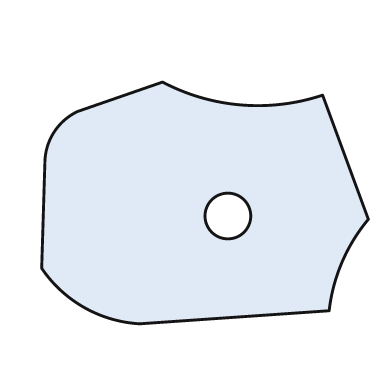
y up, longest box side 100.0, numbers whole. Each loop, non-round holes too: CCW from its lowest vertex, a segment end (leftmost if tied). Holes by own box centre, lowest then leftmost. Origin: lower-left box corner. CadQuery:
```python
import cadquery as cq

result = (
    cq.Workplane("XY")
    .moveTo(30.0, 0.0)
    .lineTo(88.0, 4.0)
    .threePointArc((92.0, 19.0), (100.0, 32.0))
    .lineTo(86.0, 70.0)
    .threePointArc((61.0, 67.0), (37.0, 74.0))
    .lineTo(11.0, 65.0)
    .threePointArc((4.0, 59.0), (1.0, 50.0))
    .lineTo(0.0, 17.0)
    .threePointArc((13.0, 5.0), (30.0, 0.0))
    .close()
    .moveTo(57.0, 33.0)
    .circle(7.0)
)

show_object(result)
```